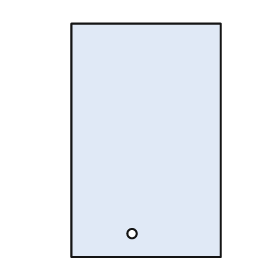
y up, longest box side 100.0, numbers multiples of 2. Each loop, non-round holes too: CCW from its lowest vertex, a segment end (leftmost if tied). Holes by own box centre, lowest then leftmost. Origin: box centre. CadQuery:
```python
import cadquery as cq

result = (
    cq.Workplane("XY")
    .moveTo(-32.0, -50.0)
    .lineTo(32.0, -50.0)
    .lineTo(32.0, 50.0)
    .lineTo(-32.0, 50.0)
    .close()
    .moveTo(-6.0, -40.0)
    .circle(2.0)
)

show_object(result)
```